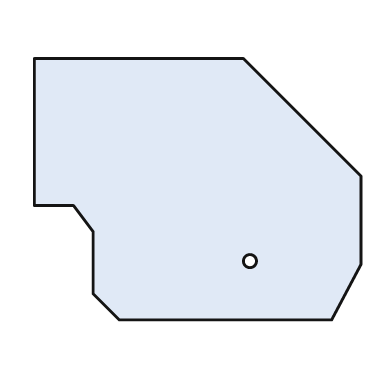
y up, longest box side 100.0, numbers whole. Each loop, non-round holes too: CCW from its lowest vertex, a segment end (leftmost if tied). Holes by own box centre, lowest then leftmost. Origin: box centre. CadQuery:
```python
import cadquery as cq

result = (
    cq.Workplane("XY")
    .moveTo(-24.0, -40.0)
    .lineTo(41.0, -40.0)
    .lineTo(50.0, -23.0)
    .lineTo(50.0, 4.0)
    .lineTo(14.0, 40.0)
    .lineTo(-50.0, 40.0)
    .lineTo(-50.0, -5.0)
    .lineTo(-38.0, -5.0)
    .lineTo(-32.0, -13.0)
    .lineTo(-32.0, -32.0)
    .close()
    .moveTo(16.0, -22.0)
    .circle(2.0)
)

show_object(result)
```